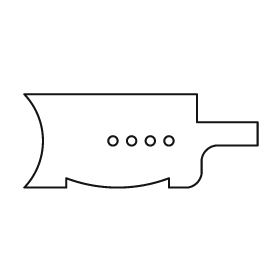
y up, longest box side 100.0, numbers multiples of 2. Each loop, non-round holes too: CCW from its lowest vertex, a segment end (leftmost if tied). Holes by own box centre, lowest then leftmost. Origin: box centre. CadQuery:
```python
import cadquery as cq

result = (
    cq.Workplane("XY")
    .moveTo(-50.0, -20.0)
    .lineTo(-32.0, -20.0)
    .lineTo(-32.0, -16.0)
    .threePointArc((-10.0, -20.0), (12.0, -16.0))
    .lineTo(12.0, -20.0)
    .lineTo(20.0, -20.0)
    .threePointArc((24.0, -18.0), (26.0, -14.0))
    .lineTo(26.0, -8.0)
    .threePointArc((28.0, -4.0), (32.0, -2.0))
    .lineTo(50.0, -2.0)
    .lineTo(50.0, 8.0)
    .lineTo(24.0, 8.0)
    .lineTo(24.0, 20.0)
    .lineTo(-50.0, 20.0)
    .threePointArc((-42.0, 0.0), (-50.0, -20.0))
    .close()
    .moveTo(-12.0, 0.0)
    .circle(2.0)
    .moveTo(-4.0, 0.0)
    .circle(2.0)
    .moveTo(4.0, 0.0)
    .circle(2.0)
    .moveTo(12.0, 0.0)
    .circle(2.0)
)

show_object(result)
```